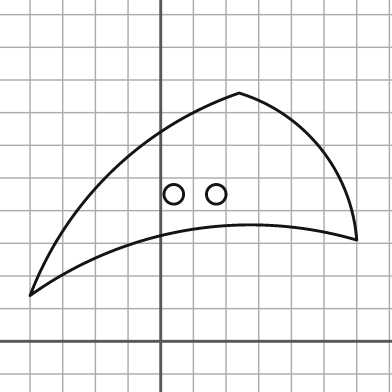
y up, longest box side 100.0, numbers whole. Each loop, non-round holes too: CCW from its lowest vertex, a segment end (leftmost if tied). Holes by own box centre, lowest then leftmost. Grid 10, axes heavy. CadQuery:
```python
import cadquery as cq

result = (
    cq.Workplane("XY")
    .moveTo(-40.0, 14.0)
    .threePointArc((8.0, 34.0), (60.0, 31.0))
    .threePointArc((49.0, 59.0), (24.0, 76.0))
    .threePointArc((-15.0, 52.0), (-40.0, 14.0))
    .close()
    .moveTo(4.0, 45.0)
    .circle(3.0)
    .moveTo(17.0, 45.0)
    .circle(3.0)
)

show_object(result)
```